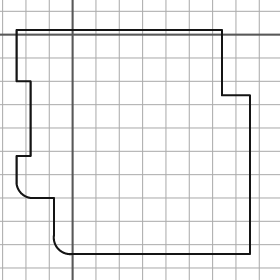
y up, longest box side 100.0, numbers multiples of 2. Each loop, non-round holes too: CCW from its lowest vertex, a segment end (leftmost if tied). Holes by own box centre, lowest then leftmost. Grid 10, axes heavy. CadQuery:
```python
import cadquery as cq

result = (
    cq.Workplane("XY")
    .moveTo(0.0, -94.0)
    .lineTo(76.0, -94.0)
    .lineTo(76.0, -26.0)
    .lineTo(64.0, -26.0)
    .lineTo(64.0, 2.0)
    .lineTo(-24.0, 2.0)
    .lineTo(-24.0, -20.0)
    .lineTo(-18.0, -20.0)
    .lineTo(-18.0, -52.0)
    .lineTo(-24.0, -52.0)
    .lineTo(-24.0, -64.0)
    .threePointArc((-22.0, -68.0), (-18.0, -70.0))
    .lineTo(-8.0, -70.0)
    .lineTo(-8.0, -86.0)
    .threePointArc((-6.0, -92.0), (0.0, -94.0))
    .close()
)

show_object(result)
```